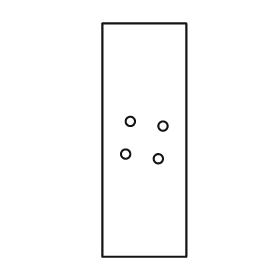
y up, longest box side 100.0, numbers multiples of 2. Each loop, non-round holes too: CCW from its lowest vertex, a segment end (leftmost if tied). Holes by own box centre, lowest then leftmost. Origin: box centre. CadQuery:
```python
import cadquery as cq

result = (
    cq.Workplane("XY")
    .moveTo(-18.0, -50.0)
    .lineTo(18.0, -50.0)
    .lineTo(18.0, 50.0)
    .lineTo(-18.0, 50.0)
    .close()
    .moveTo(6.0, -8.0)
    .circle(2.0)
    .moveTo(-8.0, -6.0)
    .circle(2.0)
    .moveTo(8.0, 6.0)
    .circle(2.0)
    .moveTo(-6.0, 8.0)
    .circle(2.0)
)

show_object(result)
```